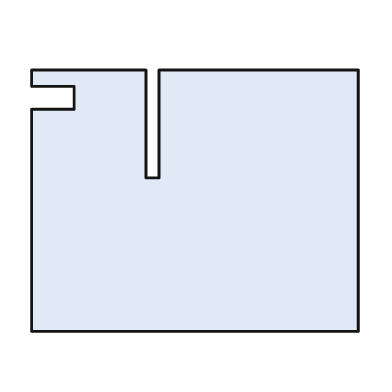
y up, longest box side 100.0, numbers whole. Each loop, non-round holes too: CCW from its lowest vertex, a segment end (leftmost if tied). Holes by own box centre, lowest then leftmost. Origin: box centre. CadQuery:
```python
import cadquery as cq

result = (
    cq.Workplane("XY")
    .moveTo(-50.0, -40.0)
    .lineTo(50.0, -40.0)
    .lineTo(50.0, 40.0)
    .lineTo(-11.0, 40.0)
    .lineTo(-11.0, 7.0)
    .lineTo(-15.0, 7.0)
    .lineTo(-15.0, 40.0)
    .lineTo(-50.0, 40.0)
    .lineTo(-50.0, 35.0)
    .lineTo(-37.0, 35.0)
    .lineTo(-37.0, 28.0)
    .lineTo(-50.0, 28.0)
    .close()
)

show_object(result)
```